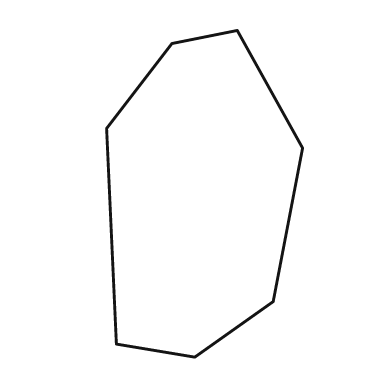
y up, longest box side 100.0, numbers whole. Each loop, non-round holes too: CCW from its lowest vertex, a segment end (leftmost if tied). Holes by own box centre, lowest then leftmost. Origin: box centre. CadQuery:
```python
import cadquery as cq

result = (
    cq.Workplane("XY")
    .moveTo(-3.0, -50.0)
    .lineTo(21.0, -33.0)
    .lineTo(30.0, 14.0)
    .lineTo(10.0, 50.0)
    .lineTo(-10.0, 46.0)
    .lineTo(-30.0, 20.0)
    .lineTo(-27.0, -46.0)
    .close()
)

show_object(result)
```